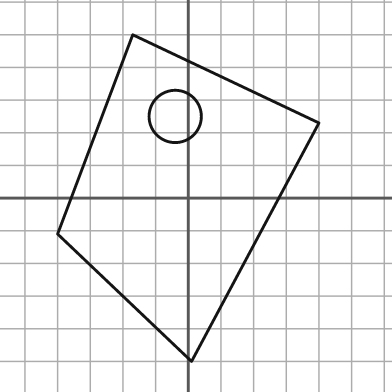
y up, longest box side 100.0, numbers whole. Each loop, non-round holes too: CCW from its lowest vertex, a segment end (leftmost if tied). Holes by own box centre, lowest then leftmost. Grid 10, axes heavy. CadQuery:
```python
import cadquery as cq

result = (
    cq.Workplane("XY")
    .moveTo(1.0, -50.0)
    .lineTo(40.0, 23.0)
    .lineTo(-17.0, 50.0)
    .lineTo(-40.0, -11.0)
    .close()
    .moveTo(-4.0, 25.0)
    .circle(8.0)
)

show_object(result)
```